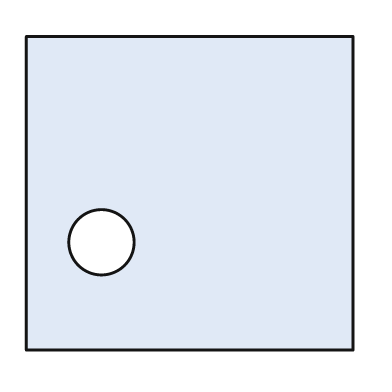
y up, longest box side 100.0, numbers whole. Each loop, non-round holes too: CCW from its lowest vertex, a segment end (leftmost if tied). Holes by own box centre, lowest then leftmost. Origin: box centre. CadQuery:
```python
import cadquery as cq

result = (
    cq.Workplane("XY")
    .moveTo(-50.0, -48.0)
    .lineTo(50.0, -48.0)
    .lineTo(50.0, 48.0)
    .lineTo(-50.0, 48.0)
    .close()
    .moveTo(-27.0, -15.0)
    .circle(10.0)
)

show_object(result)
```